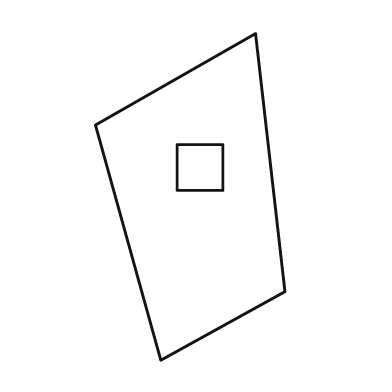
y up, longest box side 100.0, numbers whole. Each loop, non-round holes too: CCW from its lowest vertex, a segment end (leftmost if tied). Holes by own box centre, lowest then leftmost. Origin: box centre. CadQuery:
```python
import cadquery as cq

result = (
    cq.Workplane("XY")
    .moveTo(-9.0, -50.0)
    .lineTo(29.0, -29.0)
    .lineTo(20.0, 50.0)
    .lineTo(-29.0, 22.0)
    .close()
    .moveTo(-4.0, 2.0)
    .lineTo(10.0, 2.0)
    .lineTo(10.0, 16.0)
    .lineTo(-4.0, 16.0)
    .close()
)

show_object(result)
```